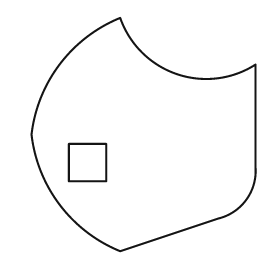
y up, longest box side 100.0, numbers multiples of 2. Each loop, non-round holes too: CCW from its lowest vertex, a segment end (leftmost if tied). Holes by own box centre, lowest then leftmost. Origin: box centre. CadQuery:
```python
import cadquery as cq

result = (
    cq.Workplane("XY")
    .moveTo(-10.0, -50.0)
    .lineTo(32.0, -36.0)
    .threePointArc((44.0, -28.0), (48.0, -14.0))
    .lineTo(48.0, 30.0)
    .threePointArc((14.0, 26.0), (-10.0, 50.0))
    .threePointArc((-36.0, 30.0), (-48.0, 0.0))
    .threePointArc((-36.0, -30.0), (-10.0, -50.0))
    .close()
    .moveTo(-32.0, -20.0)
    .lineTo(-16.0, -20.0)
    .lineTo(-16.0, -4.0)
    .lineTo(-32.0, -4.0)
    .close()
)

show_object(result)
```